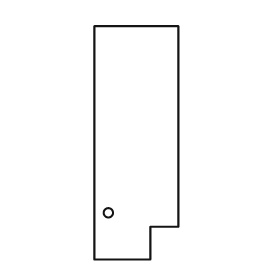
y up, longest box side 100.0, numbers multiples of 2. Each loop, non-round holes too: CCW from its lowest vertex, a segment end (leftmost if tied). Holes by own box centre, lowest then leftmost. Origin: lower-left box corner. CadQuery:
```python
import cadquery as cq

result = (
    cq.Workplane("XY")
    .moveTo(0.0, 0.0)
    .lineTo(24.0, 0.0)
    .lineTo(24.0, 14.0)
    .lineTo(36.0, 14.0)
    .lineTo(36.0, 100.0)
    .lineTo(0.0, 100.0)
    .close()
    .moveTo(6.0, 20.0)
    .circle(2.0)
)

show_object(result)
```